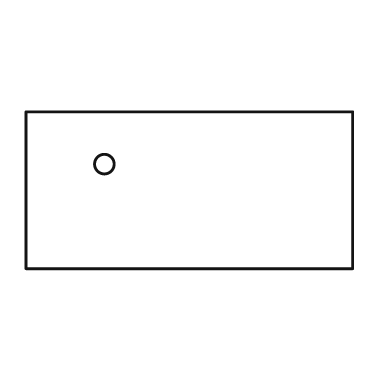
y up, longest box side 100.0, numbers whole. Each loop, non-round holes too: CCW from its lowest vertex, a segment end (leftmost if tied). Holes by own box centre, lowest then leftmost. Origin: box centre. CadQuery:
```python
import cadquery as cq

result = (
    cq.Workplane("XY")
    .moveTo(-50.0, -24.0)
    .lineTo(50.0, -24.0)
    .lineTo(50.0, 24.0)
    .lineTo(-50.0, 24.0)
    .close()
    .moveTo(-26.0, 8.0)
    .circle(3.0)
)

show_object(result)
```